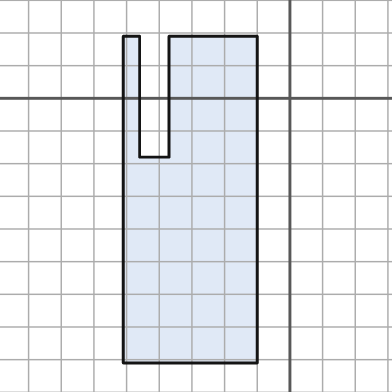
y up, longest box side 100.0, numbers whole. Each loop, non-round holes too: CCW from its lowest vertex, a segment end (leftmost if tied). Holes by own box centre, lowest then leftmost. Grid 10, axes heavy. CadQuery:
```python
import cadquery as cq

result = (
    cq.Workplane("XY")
    .moveTo(-51.0, -81.0)
    .lineTo(-10.0, -81.0)
    .lineTo(-10.0, 19.0)
    .lineTo(-37.0, 19.0)
    .lineTo(-37.0, -18.0)
    .lineTo(-46.0, -18.0)
    .lineTo(-46.0, 19.0)
    .lineTo(-51.0, 19.0)
    .close()
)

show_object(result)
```